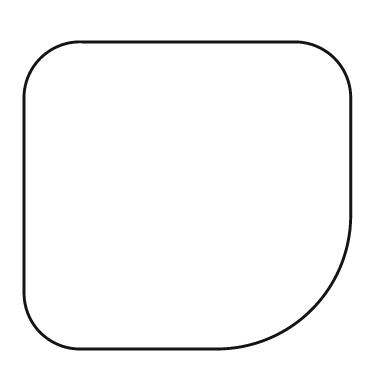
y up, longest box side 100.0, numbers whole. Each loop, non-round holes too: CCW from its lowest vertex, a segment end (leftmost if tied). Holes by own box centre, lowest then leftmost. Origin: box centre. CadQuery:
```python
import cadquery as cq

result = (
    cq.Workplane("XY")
    .moveTo(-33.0, -47.0)
    .lineTo(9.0, -47.0)
    .threePointArc((38.0, -35.0), (50.0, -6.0))
    .lineTo(50.0, 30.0)
    .threePointArc((45.0, 42.0), (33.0, 47.0))
    .lineTo(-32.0, 47.0)
    .threePointArc((-45.0, 42.0), (-50.0, 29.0))
    .lineTo(-50.0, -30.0)
    .threePointArc((-45.0, -42.0), (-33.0, -47.0))
    .close()
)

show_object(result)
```